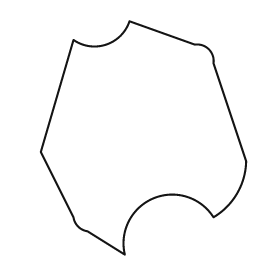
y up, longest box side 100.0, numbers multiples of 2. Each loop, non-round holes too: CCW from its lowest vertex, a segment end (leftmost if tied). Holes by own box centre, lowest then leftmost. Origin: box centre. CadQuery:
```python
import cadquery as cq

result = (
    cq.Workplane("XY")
    .moveTo(-8.0, -50.0)
    .threePointArc((4.0, -26.0), (30.0, -34.0))
    .threePointArc((40.0, -24.0), (44.0, -10.0))
    .lineTo(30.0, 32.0)
    .threePointArc((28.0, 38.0), (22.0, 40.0))
    .lineTo(-6.0, 50.0)
    .threePointArc((-16.0, 40.0), (-30.0, 42.0))
    .lineTo(-44.0, -6.0)
    .lineTo(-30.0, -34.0)
    .threePointArc((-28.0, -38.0), (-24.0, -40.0))
    .close()
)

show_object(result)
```